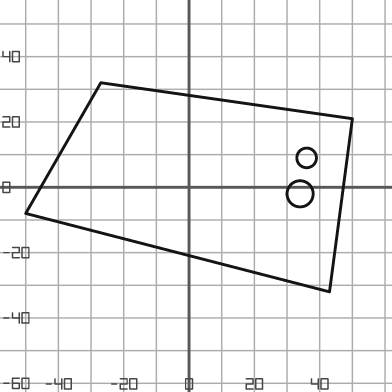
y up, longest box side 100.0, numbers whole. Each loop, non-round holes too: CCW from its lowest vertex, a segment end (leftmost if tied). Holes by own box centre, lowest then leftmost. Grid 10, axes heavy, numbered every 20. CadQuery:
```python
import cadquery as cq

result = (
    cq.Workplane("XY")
    .moveTo(43.0, -32.0)
    .lineTo(50.0, 21.0)
    .lineTo(-27.0, 32.0)
    .lineTo(-50.0, -8.0)
    .close()
    .moveTo(34.0, -2.0)
    .circle(4.0)
    .moveTo(36.0, 9.0)
    .circle(3.0)
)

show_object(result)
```